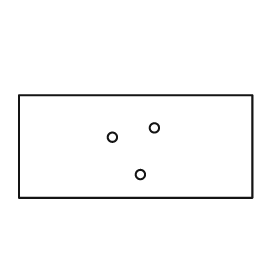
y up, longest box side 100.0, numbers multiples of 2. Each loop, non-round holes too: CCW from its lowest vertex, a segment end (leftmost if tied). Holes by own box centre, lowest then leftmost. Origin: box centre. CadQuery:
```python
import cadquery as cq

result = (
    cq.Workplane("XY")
    .moveTo(-50.0, -22.0)
    .lineTo(50.0, -22.0)
    .lineTo(50.0, 22.0)
    .lineTo(-50.0, 22.0)
    .close()
    .moveTo(2.0, -12.0)
    .circle(2.0)
    .moveTo(-10.0, 4.0)
    .circle(2.0)
    .moveTo(8.0, 8.0)
    .circle(2.0)
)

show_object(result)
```